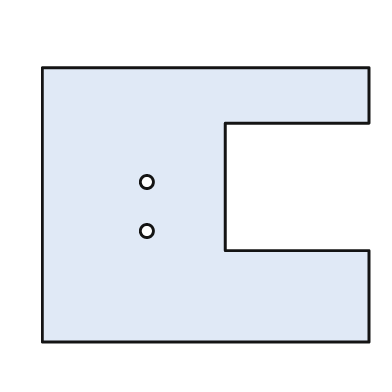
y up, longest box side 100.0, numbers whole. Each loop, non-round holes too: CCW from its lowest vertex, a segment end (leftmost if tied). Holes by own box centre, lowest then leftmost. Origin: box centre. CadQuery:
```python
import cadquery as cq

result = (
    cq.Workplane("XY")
    .moveTo(-50.0, -42.0)
    .lineTo(50.0, -42.0)
    .lineTo(50.0, -14.0)
    .lineTo(6.0, -14.0)
    .lineTo(6.0, 25.0)
    .lineTo(50.0, 25.0)
    .lineTo(50.0, 42.0)
    .lineTo(-50.0, 42.0)
    .close()
    .moveTo(-18.0, -8.0)
    .circle(2.0)
    .moveTo(-18.0, 7.0)
    .circle(2.0)
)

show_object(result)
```